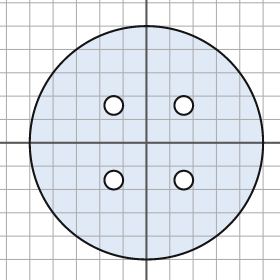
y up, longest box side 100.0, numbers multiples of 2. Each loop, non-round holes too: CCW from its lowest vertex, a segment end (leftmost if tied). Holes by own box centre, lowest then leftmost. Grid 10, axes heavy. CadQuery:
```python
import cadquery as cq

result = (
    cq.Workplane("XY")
    .moveTo(0.0, 0.0)
    .circle(50.0)
    .moveTo(-14.0, -16.0)
    .circle(4.0)
    .moveTo(16.0, -16.0)
    .circle(4.0)
    .moveTo(-14.0, 16.0)
    .circle(4.0)
    .moveTo(16.0, 16.0)
    .circle(4.0)
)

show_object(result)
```